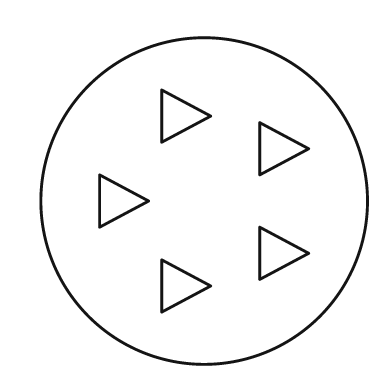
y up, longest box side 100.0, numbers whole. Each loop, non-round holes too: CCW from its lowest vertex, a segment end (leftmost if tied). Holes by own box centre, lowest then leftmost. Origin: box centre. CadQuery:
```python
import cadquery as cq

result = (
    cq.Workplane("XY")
    .moveTo(0.0, 0.0)
    .circle(50.0)
    .moveTo(-13.0, -34.0)
    .lineTo(2.0, -26.0)
    .lineTo(-13.0, -18.0)
    .close()
    .moveTo(17.0, -24.0)
    .lineTo(32.0, -16.0)
    .lineTo(17.0, -8.0)
    .close()
    .moveTo(-32.0, -8.0)
    .lineTo(-17.0, 0.0)
    .lineTo(-32.0, 8.0)
    .close()
    .moveTo(17.0, 8.0)
    .lineTo(32.0, 16.0)
    .lineTo(17.0, 24.0)
    .close()
    .moveTo(-13.0, 18.0)
    .lineTo(2.0, 26.0)
    .lineTo(-13.0, 34.0)
    .close()
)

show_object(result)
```